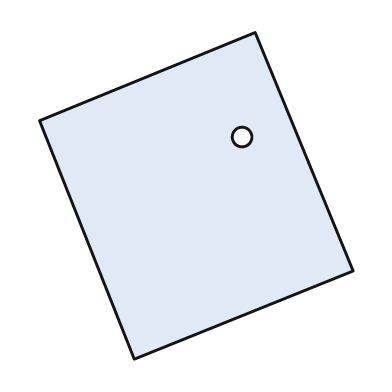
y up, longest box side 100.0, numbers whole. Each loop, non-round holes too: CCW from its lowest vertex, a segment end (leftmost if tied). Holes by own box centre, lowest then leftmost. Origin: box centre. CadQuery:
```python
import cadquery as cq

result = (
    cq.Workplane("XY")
    .moveTo(-19.0, -50.0)
    .lineTo(48.0, -23.0)
    .lineTo(18.0, 50.0)
    .lineTo(-48.0, 23.0)
    .close()
    .moveTo(14.0, 18.0)
    .circle(3.0)
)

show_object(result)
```